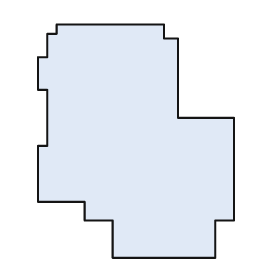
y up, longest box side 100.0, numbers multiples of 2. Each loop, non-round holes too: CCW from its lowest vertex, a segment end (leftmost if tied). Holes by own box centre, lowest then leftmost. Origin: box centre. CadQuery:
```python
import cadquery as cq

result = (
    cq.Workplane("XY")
    .moveTo(-10.0, -50.0)
    .lineTo(34.0, -50.0)
    .lineTo(34.0, -34.0)
    .lineTo(42.0, -34.0)
    .lineTo(42.0, 10.0)
    .lineTo(18.0, 10.0)
    .lineTo(18.0, 44.0)
    .lineTo(12.0, 44.0)
    .lineTo(12.0, 50.0)
    .lineTo(-34.0, 50.0)
    .lineTo(-34.0, 46.0)
    .lineTo(-38.0, 46.0)
    .lineTo(-38.0, 36.0)
    .lineTo(-42.0, 36.0)
    .lineTo(-42.0, 22.0)
    .lineTo(-38.0, 22.0)
    .lineTo(-38.0, -2.0)
    .lineTo(-42.0, -2.0)
    .lineTo(-42.0, -26.0)
    .lineTo(-22.0, -26.0)
    .lineTo(-22.0, -34.0)
    .lineTo(-10.0, -34.0)
    .close()
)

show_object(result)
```